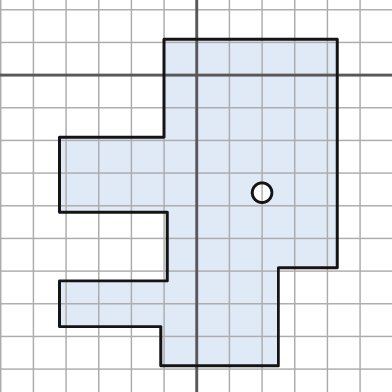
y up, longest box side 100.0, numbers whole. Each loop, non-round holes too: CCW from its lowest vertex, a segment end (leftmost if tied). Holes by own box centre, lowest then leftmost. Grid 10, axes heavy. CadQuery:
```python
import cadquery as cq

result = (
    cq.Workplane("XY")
    .moveTo(-11.0, -89.0)
    .lineTo(25.0, -89.0)
    .lineTo(25.0, -59.0)
    .lineTo(43.0, -59.0)
    .lineTo(43.0, 11.0)
    .lineTo(-10.0, 11.0)
    .lineTo(-10.0, -19.0)
    .lineTo(-42.0, -19.0)
    .lineTo(-42.0, -42.0)
    .lineTo(-9.0, -42.0)
    .lineTo(-9.0, -63.0)
    .lineTo(-42.0, -63.0)
    .lineTo(-42.0, -77.0)
    .lineTo(-11.0, -77.0)
    .close()
    .moveTo(20.0, -36.0)
    .circle(3.0)
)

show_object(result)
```